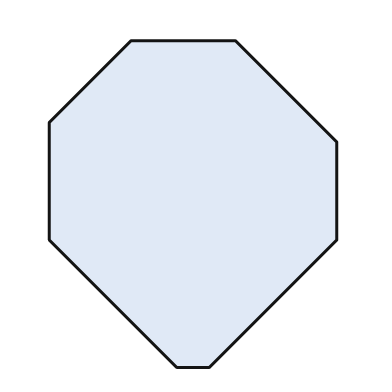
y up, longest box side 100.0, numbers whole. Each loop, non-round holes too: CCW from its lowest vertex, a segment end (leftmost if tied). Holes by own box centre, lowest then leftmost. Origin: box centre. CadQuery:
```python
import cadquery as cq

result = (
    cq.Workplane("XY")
    .moveTo(-5.0, -50.0)
    .lineTo(5.0, -50.0)
    .lineTo(44.0, -11.0)
    .lineTo(44.0, 19.0)
    .lineTo(13.0, 50.0)
    .lineTo(-19.0, 50.0)
    .lineTo(-44.0, 25.0)
    .lineTo(-44.0, -11.0)
    .close()
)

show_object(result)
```